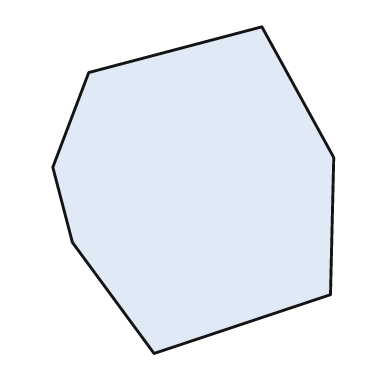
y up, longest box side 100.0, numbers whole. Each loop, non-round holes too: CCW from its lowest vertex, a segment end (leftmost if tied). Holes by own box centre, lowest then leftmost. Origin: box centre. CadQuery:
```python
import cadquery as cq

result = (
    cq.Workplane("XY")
    .moveTo(-12.0, -50.0)
    .lineTo(42.0, -32.0)
    .lineTo(43.0, 10.0)
    .lineTo(21.0, 50.0)
    .lineTo(-32.0, 36.0)
    .lineTo(-43.0, 7.0)
    .lineTo(-37.0, -16.0)
    .close()
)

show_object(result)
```